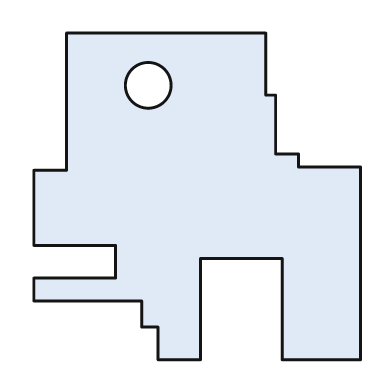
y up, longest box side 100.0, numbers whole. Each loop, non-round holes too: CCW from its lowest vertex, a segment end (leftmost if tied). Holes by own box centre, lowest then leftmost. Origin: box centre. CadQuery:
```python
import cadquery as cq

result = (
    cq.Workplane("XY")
    .moveTo(-12.0, -50.0)
    .lineTo(1.0, -50.0)
    .lineTo(1.0, -19.0)
    .lineTo(26.0, -19.0)
    .lineTo(26.0, -50.0)
    .lineTo(50.0, -50.0)
    .lineTo(50.0, 9.0)
    .lineTo(31.0, 9.0)
    .lineTo(31.0, 13.0)
    .lineTo(24.0, 13.0)
    .lineTo(24.0, 31.0)
    .lineTo(21.0, 31.0)
    .lineTo(21.0, 50.0)
    .lineTo(-40.0, 50.0)
    .lineTo(-40.0, 8.0)
    .lineTo(-50.0, 8.0)
    .lineTo(-50.0, -15.0)
    .lineTo(-25.0, -15.0)
    .lineTo(-25.0, -25.0)
    .lineTo(-50.0, -25.0)
    .lineTo(-50.0, -32.0)
    .lineTo(-17.0, -32.0)
    .lineTo(-17.0, -40.0)
    .lineTo(-12.0, -40.0)
    .close()
    .moveTo(-15.0, 34.0)
    .circle(7.0)
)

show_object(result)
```